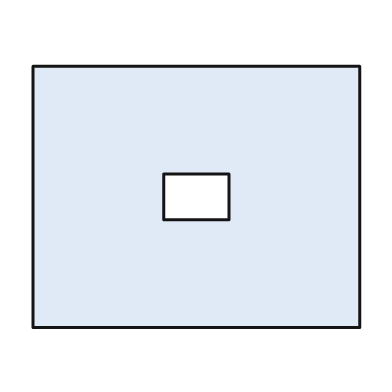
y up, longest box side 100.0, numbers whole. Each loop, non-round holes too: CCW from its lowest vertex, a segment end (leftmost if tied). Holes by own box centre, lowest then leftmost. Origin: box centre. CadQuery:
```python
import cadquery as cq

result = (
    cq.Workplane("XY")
    .moveTo(-50.0, -40.0)
    .lineTo(50.0, -40.0)
    .lineTo(50.0, 40.0)
    .lineTo(-50.0, 40.0)
    .close()
    .moveTo(-10.0, -7.0)
    .lineTo(10.0, -7.0)
    .lineTo(10.0, 7.0)
    .lineTo(-10.0, 7.0)
    .close()
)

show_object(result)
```